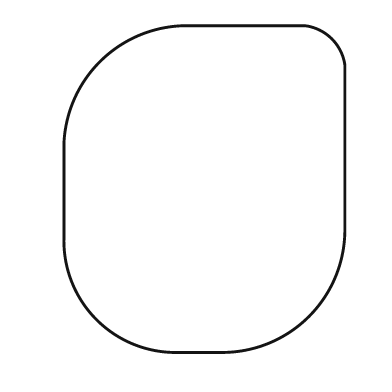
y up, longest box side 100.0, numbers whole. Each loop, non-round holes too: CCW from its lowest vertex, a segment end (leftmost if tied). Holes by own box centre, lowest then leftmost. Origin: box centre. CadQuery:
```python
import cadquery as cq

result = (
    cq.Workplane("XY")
    .moveTo(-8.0, -50.0)
    .lineTo(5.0, -50.0)
    .threePointArc((32.0, -39.0), (43.0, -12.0))
    .lineTo(43.0, 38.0)
    .threePointArc((39.0, 46.0), (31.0, 50.0))
    .lineTo(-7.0, 50.0)
    .threePointArc((-32.0, 39.0), (-43.0, 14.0))
    .lineTo(-43.0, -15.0)
    .threePointArc((-33.0, -40.0), (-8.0, -50.0))
    .close()
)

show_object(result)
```